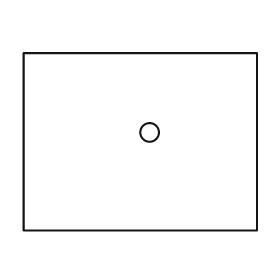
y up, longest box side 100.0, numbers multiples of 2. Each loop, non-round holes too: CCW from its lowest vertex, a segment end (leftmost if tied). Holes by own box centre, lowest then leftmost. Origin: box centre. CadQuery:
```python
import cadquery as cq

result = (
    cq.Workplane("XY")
    .moveTo(-50.0, -38.0)
    .lineTo(50.0, -38.0)
    .lineTo(50.0, 38.0)
    .lineTo(-50.0, 38.0)
    .close()
    .moveTo(4.0, 4.0)
    .circle(4.0)
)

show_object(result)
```